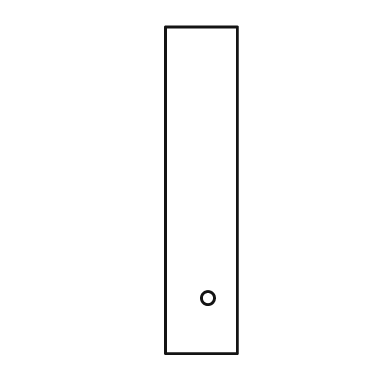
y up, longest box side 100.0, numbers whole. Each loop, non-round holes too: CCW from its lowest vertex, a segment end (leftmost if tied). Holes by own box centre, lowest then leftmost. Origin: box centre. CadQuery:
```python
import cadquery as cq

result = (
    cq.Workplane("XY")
    .moveTo(-11.0, -50.0)
    .lineTo(11.0, -50.0)
    .lineTo(11.0, 50.0)
    .lineTo(-11.0, 50.0)
    .close()
    .moveTo(2.0, -33.0)
    .circle(2.0)
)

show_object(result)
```